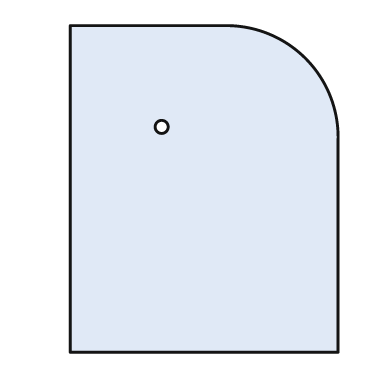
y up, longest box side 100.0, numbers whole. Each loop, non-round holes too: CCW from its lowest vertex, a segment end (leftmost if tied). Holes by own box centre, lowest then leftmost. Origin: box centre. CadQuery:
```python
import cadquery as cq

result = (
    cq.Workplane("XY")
    .moveTo(-41.0, -50.0)
    .lineTo(41.0, -50.0)
    .lineTo(41.0, 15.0)
    .threePointArc((31.0, 40.0), (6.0, 50.0))
    .lineTo(-41.0, 50.0)
    .close()
    .moveTo(-13.0, 19.0)
    .circle(2.0)
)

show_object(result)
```